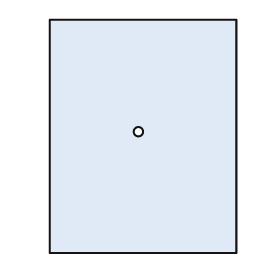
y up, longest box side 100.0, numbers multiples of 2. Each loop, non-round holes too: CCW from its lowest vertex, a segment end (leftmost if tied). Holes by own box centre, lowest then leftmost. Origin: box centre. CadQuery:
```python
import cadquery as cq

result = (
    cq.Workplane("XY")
    .moveTo(-40.0, -50.0)
    .lineTo(40.0, -50.0)
    .lineTo(40.0, 50.0)
    .lineTo(-40.0, 50.0)
    .close()
    .moveTo(-2.0, 2.0)
    .circle(2.0)
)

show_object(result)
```